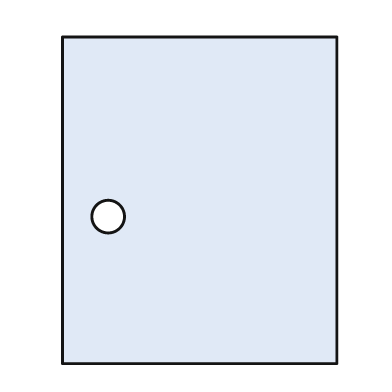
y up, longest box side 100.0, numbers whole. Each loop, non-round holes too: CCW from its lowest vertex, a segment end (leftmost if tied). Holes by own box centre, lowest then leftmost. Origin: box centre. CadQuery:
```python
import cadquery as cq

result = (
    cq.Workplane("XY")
    .moveTo(-42.0, -50.0)
    .lineTo(42.0, -50.0)
    .lineTo(42.0, 50.0)
    .lineTo(-42.0, 50.0)
    .close()
    .moveTo(-28.0, -5.0)
    .circle(5.0)
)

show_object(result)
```